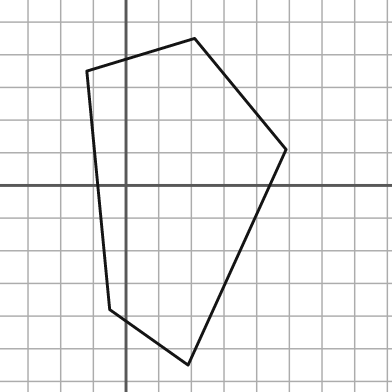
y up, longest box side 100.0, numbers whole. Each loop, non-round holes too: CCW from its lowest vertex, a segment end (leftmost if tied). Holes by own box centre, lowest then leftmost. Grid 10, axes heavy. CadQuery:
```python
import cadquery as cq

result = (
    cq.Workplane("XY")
    .moveTo(19.0, -55.0)
    .lineTo(49.0, 11.0)
    .lineTo(21.0, 45.0)
    .lineTo(-12.0, 35.0)
    .lineTo(-5.0, -38.0)
    .close()
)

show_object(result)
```